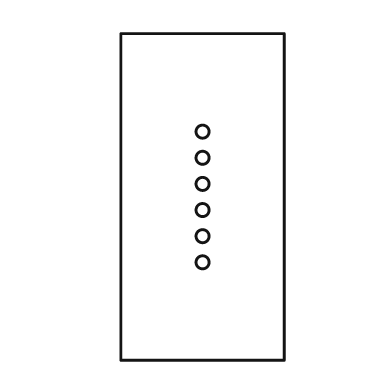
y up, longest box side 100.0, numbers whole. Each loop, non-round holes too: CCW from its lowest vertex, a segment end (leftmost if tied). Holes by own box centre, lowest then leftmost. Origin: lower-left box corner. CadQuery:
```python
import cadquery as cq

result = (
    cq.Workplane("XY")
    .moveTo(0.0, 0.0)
    .lineTo(50.0, 0.0)
    .lineTo(50.0, 100.0)
    .lineTo(0.0, 100.0)
    .close()
    .moveTo(25.0, 30.0)
    .circle(2.0)
    .moveTo(25.0, 38.0)
    .circle(2.0)
    .moveTo(25.0, 46.0)
    .circle(2.0)
    .moveTo(25.0, 54.0)
    .circle(2.0)
    .moveTo(25.0, 62.0)
    .circle(2.0)
    .moveTo(25.0, 70.0)
    .circle(2.0)
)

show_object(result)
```